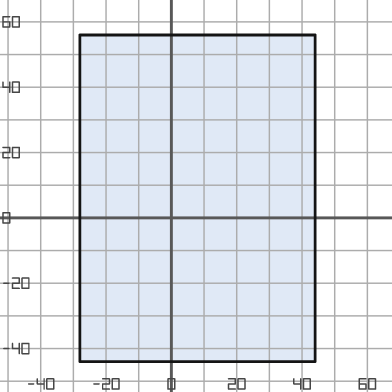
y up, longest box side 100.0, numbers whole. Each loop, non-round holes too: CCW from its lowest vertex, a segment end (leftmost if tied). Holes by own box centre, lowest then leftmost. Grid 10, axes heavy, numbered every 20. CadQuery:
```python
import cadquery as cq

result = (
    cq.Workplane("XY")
    .moveTo(-28.0, -44.0)
    .lineTo(44.0, -44.0)
    .lineTo(44.0, 56.0)
    .lineTo(-28.0, 56.0)
    .close()
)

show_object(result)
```